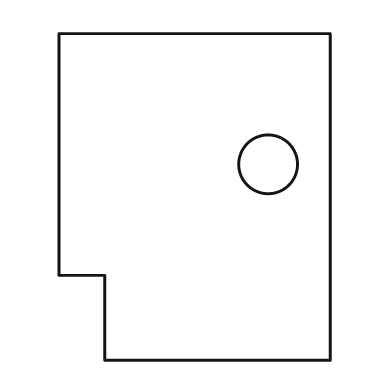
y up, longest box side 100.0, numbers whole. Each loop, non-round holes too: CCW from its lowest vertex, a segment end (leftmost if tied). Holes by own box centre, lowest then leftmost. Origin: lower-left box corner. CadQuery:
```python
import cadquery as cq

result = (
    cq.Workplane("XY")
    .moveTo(14.0, 0.0)
    .lineTo(83.0, 0.0)
    .lineTo(83.0, 100.0)
    .lineTo(0.0, 100.0)
    .lineTo(0.0, 26.0)
    .lineTo(14.0, 26.0)
    .close()
    .moveTo(64.0, 60.0)
    .circle(9.0)
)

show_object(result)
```